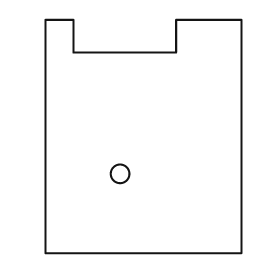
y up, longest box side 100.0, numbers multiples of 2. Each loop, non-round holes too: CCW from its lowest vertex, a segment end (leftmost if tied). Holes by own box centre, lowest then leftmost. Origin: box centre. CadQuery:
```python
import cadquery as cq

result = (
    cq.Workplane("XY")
    .moveTo(-42.0, -50.0)
    .lineTo(42.0, -50.0)
    .lineTo(42.0, 50.0)
    .lineTo(14.0, 50.0)
    .lineTo(14.0, 36.0)
    .lineTo(-30.0, 36.0)
    .lineTo(-30.0, 50.0)
    .lineTo(-42.0, 50.0)
    .close()
    .moveTo(-10.0, -16.0)
    .circle(4.0)
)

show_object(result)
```